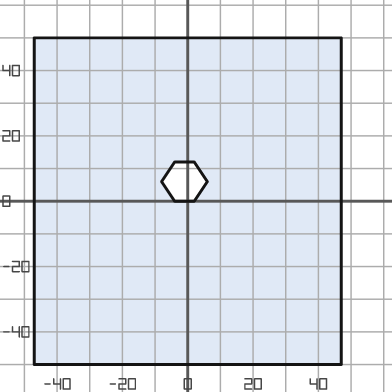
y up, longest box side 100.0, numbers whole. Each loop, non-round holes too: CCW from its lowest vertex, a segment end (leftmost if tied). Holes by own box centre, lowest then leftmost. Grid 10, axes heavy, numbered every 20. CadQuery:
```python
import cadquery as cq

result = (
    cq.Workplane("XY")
    .moveTo(-47.0, -50.0)
    .lineTo(47.0, -50.0)
    .lineTo(47.0, 50.0)
    .lineTo(-47.0, 50.0)
    .close()
    .moveTo(-4.0, 0.0)
    .lineTo(2.0, 0.0)
    .lineTo(6.0, 6.0)
    .lineTo(2.0, 12.0)
    .lineTo(-4.0, 12.0)
    .lineTo(-8.0, 6.0)
    .close()
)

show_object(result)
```